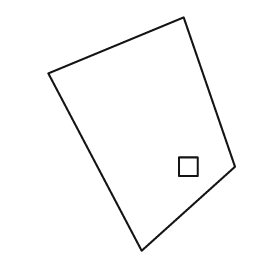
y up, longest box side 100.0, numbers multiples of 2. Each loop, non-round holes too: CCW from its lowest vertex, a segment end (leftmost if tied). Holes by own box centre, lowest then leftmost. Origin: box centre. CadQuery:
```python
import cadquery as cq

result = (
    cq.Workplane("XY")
    .moveTo(0.0, -50.0)
    .lineTo(40.0, -14.0)
    .lineTo(18.0, 50.0)
    .lineTo(-40.0, 26.0)
    .close()
    .moveTo(16.0, -18.0)
    .lineTo(24.0, -18.0)
    .lineTo(24.0, -10.0)
    .lineTo(16.0, -10.0)
    .close()
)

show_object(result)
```